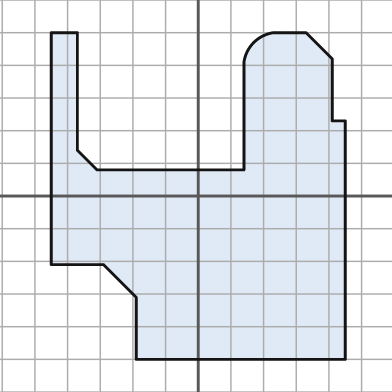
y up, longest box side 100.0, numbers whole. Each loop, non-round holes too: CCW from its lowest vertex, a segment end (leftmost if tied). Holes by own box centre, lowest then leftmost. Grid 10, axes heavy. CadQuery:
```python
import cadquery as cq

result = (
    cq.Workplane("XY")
    .moveTo(-19.0, -50.0)
    .lineTo(45.0, -50.0)
    .lineTo(45.0, 23.0)
    .lineTo(41.0, 23.0)
    .lineTo(41.0, 42.0)
    .lineTo(33.0, 50.0)
    .lineTo(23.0, 50.0)
    .threePointArc((17.0, 47.0), (14.0, 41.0))
    .lineTo(14.0, 8.0)
    .lineTo(-31.0, 8.0)
    .lineTo(-37.0, 14.0)
    .lineTo(-37.0, 50.0)
    .lineTo(-45.0, 50.0)
    .lineTo(-45.0, -21.0)
    .lineTo(-29.0, -21.0)
    .lineTo(-19.0, -31.0)
    .close()
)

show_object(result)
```